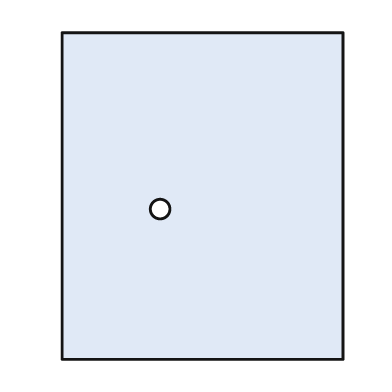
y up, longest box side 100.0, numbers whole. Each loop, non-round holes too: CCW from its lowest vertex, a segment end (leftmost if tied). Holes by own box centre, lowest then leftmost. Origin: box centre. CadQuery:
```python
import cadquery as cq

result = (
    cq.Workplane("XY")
    .moveTo(-43.0, -50.0)
    .lineTo(43.0, -50.0)
    .lineTo(43.0, 50.0)
    .lineTo(-43.0, 50.0)
    .close()
    .moveTo(-13.0, -4.0)
    .circle(3.0)
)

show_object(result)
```